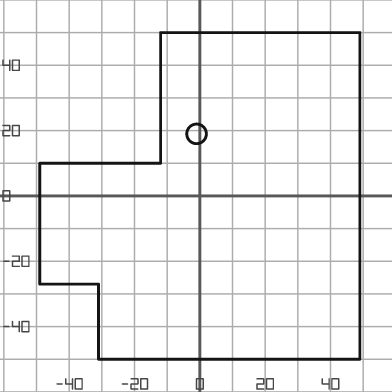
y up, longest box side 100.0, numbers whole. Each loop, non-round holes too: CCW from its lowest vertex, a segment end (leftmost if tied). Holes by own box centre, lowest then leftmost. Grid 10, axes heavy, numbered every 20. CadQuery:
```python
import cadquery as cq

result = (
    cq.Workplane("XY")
    .moveTo(-31.0, -50.0)
    .lineTo(49.0, -50.0)
    .lineTo(49.0, 50.0)
    .lineTo(-12.0, 50.0)
    .lineTo(-12.0, 10.0)
    .lineTo(-49.0, 10.0)
    .lineTo(-49.0, -27.0)
    .lineTo(-31.0, -27.0)
    .close()
    .moveTo(-1.0, 19.0)
    .circle(3.0)
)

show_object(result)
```